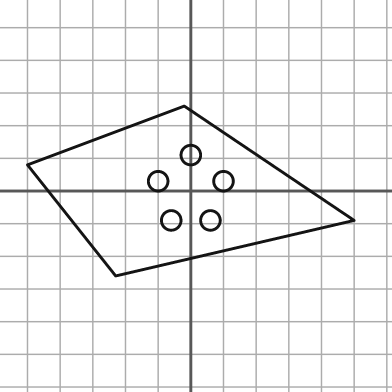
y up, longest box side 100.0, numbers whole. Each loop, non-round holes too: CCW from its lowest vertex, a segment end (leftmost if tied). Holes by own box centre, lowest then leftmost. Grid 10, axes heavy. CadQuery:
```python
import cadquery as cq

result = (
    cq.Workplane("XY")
    .moveTo(-23.0, -26.0)
    .lineTo(50.0, -9.0)
    .lineTo(-2.0, 26.0)
    .lineTo(-50.0, 8.0)
    .close()
    .moveTo(-6.0, -9.0)
    .circle(3.0)
    .moveTo(6.0, -9.0)
    .circle(3.0)
    .moveTo(-10.0, 3.0)
    .circle(3.0)
    .moveTo(10.0, 3.0)
    .circle(3.0)
    .moveTo(0.0, 11.0)
    .circle(3.0)
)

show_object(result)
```